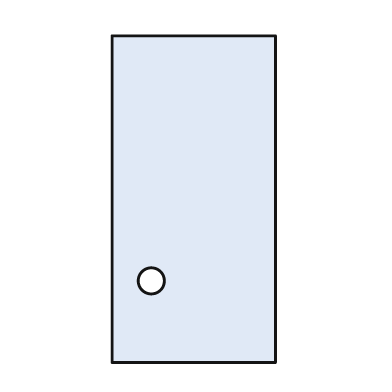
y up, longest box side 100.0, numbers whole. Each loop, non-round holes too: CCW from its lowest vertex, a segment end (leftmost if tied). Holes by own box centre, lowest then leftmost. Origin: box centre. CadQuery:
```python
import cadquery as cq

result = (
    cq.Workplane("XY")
    .moveTo(-25.0, -50.0)
    .lineTo(25.0, -50.0)
    .lineTo(25.0, 50.0)
    .lineTo(-25.0, 50.0)
    .close()
    .moveTo(-13.0, -25.0)
    .circle(4.0)
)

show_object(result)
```